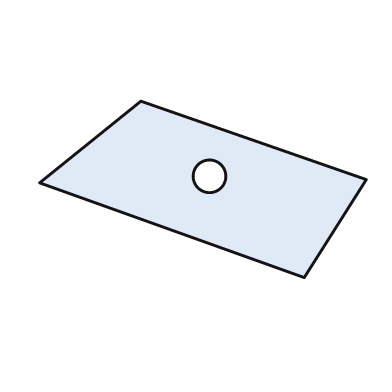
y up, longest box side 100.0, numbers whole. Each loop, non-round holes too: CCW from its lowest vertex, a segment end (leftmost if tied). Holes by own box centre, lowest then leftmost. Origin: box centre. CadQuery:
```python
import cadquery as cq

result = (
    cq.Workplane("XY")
    .moveTo(31.0, -27.0)
    .lineTo(50.0, 3.0)
    .lineTo(-19.0, 27.0)
    .lineTo(-50.0, 2.0)
    .close()
    .moveTo(2.0, 4.0)
    .circle(5.0)
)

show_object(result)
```